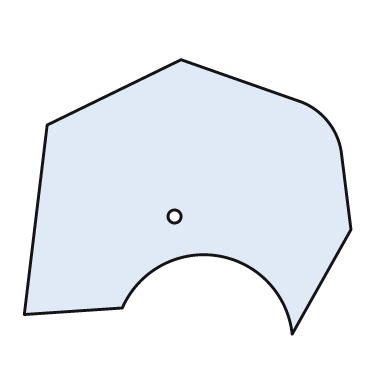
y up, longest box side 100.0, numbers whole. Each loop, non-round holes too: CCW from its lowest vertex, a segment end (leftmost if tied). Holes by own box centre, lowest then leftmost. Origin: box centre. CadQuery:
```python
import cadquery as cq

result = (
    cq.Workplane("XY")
    .moveTo(32.0, -42.0)
    .lineTo(50.0, -10.0)
    .lineTo(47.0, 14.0)
    .threePointArc((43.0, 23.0), (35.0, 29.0))
    .lineTo(-2.0, 42.0)
    .lineTo(-43.0, 22.0)
    .lineTo(-50.0, -36.0)
    .lineTo(-20.0, -34.0)
    .threePointArc((9.0, -18.0), (32.0, -42.0))
    .close()
    .moveTo(-4.0, -6.0)
    .circle(2.0)
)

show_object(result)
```